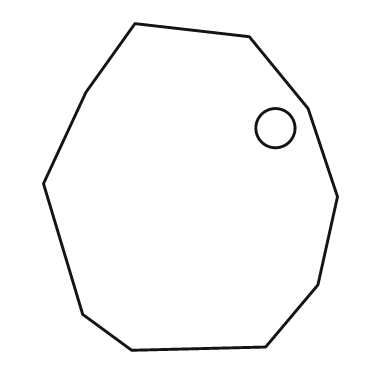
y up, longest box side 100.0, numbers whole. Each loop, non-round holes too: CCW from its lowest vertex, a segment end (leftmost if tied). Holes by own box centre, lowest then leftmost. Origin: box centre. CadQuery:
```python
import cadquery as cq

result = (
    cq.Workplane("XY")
    .moveTo(-18.0, -50.0)
    .lineTo(23.0, -49.0)
    .lineTo(39.0, -30.0)
    .lineTo(45.0, -3.0)
    .lineTo(36.0, 24.0)
    .lineTo(18.0, 46.0)
    .lineTo(-17.0, 50.0)
    .lineTo(-32.0, 29.0)
    .lineTo(-45.0, 1.0)
    .lineTo(-33.0, -39.0)
    .close()
    .moveTo(26.0, 18.0)
    .circle(6.0)
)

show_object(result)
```